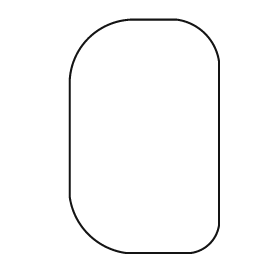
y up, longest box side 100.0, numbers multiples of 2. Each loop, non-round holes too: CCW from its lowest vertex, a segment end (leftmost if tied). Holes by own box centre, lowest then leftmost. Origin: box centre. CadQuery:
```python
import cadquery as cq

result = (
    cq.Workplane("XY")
    .moveTo(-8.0, -50.0)
    .lineTo(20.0, -50.0)
    .threePointArc((28.0, -46.0), (32.0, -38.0))
    .lineTo(32.0, 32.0)
    .threePointArc((26.0, 44.0), (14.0, 50.0))
    .lineTo(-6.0, 50.0)
    .threePointArc((-24.0, 42.0), (-32.0, 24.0))
    .lineTo(-32.0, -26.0)
    .threePointArc((-24.0, -42.0), (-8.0, -50.0))
    .close()
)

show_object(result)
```